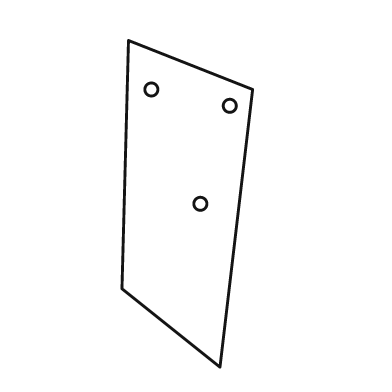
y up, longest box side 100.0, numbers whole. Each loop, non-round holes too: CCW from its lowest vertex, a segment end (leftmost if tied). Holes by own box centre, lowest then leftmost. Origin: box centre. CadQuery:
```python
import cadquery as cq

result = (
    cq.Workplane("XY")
    .moveTo(10.0, -50.0)
    .lineTo(20.0, 35.0)
    .lineTo(-18.0, 50.0)
    .lineTo(-20.0, -26.0)
    .close()
    .moveTo(4.0, 0.0)
    .circle(2.0)
    .moveTo(13.0, 30.0)
    .circle(2.0)
    .moveTo(-11.0, 35.0)
    .circle(2.0)
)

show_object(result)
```